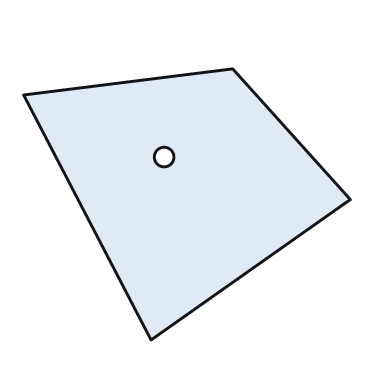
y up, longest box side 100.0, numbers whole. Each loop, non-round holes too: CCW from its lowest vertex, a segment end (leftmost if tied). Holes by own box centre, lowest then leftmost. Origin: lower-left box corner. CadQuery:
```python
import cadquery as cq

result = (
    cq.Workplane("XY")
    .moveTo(39.0, 0.0)
    .lineTo(100.0, 43.0)
    .lineTo(64.0, 83.0)
    .lineTo(0.0, 75.0)
    .close()
    .moveTo(43.0, 56.0)
    .circle(3.0)
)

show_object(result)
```